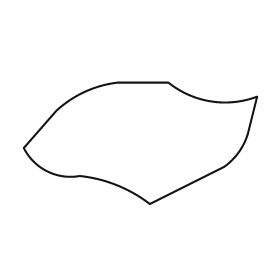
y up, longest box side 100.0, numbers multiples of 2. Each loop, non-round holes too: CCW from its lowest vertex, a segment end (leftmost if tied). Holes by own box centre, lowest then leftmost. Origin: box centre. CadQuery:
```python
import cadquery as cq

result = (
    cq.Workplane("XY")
    .moveTo(4.0, -26.0)
    .lineTo(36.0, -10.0)
    .threePointArc((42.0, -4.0), (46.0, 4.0))
    .lineTo(50.0, 20.0)
    .threePointArc((30.0, 18.0), (12.0, 26.0))
    .lineTo(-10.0, 26.0)
    .threePointArc((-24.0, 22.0), (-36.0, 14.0))
    .lineTo(-50.0, -2.0)
    .threePointArc((-40.0, -12.0), (-26.0, -14.0))
    .threePointArc((-10.0, -18.0), (4.0, -26.0))
    .close()
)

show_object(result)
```